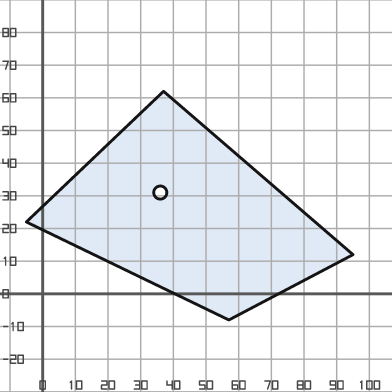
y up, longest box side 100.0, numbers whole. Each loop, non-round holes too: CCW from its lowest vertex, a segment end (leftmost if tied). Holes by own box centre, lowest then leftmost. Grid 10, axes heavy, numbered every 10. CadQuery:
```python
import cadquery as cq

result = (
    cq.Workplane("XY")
    .moveTo(57.0, -8.0)
    .lineTo(95.0, 12.0)
    .lineTo(37.0, 62.0)
    .lineTo(-5.0, 22.0)
    .close()
    .moveTo(36.0, 31.0)
    .circle(2.0)
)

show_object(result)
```